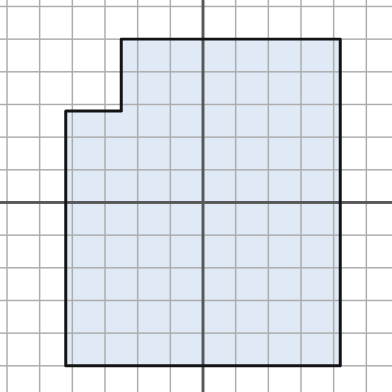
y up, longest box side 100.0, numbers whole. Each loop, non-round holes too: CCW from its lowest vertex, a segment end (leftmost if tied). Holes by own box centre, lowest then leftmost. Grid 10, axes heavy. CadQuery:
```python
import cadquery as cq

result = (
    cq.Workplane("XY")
    .moveTo(-42.0, -50.0)
    .lineTo(42.0, -50.0)
    .lineTo(42.0, 50.0)
    .lineTo(-25.0, 50.0)
    .lineTo(-25.0, 28.0)
    .lineTo(-42.0, 28.0)
    .close()
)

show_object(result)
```